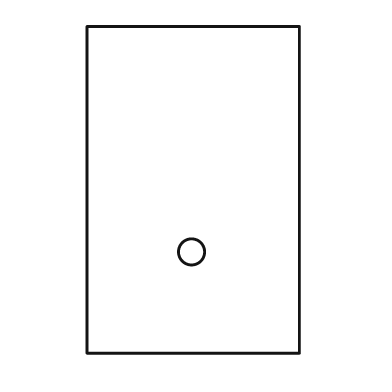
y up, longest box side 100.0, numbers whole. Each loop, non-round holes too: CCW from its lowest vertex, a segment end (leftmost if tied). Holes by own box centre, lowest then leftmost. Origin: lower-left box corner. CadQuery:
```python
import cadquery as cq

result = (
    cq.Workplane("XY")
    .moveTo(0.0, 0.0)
    .lineTo(65.0, 0.0)
    .lineTo(65.0, 100.0)
    .lineTo(0.0, 100.0)
    .close()
    .moveTo(32.0, 31.0)
    .circle(4.0)
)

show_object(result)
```